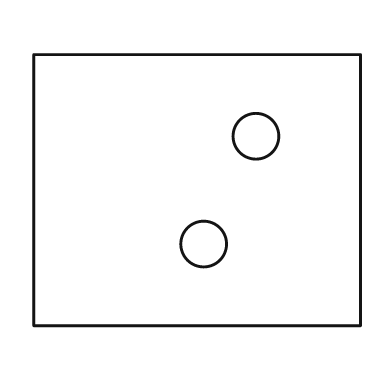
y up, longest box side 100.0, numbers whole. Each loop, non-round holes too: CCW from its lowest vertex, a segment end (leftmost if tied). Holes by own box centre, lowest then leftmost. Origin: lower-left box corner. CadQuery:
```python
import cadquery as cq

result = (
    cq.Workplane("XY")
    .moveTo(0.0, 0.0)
    .lineTo(100.0, 0.0)
    .lineTo(100.0, 83.0)
    .lineTo(0.0, 83.0)
    .close()
    .moveTo(52.0, 25.0)
    .circle(7.0)
    .moveTo(68.0, 58.0)
    .circle(7.0)
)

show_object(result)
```